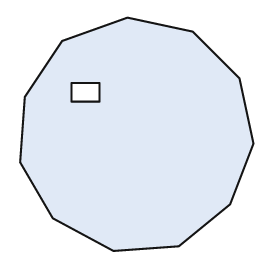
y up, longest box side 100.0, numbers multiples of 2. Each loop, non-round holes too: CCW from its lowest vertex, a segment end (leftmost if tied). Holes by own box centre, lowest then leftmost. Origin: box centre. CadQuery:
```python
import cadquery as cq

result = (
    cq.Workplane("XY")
    .moveTo(-10.0, -50.0)
    .lineTo(18.0, -48.0)
    .lineTo(40.0, -30.0)
    .lineTo(50.0, -4.0)
    .lineTo(44.0, 24.0)
    .lineTo(24.0, 44.0)
    .lineTo(-4.0, 50.0)
    .lineTo(-32.0, 40.0)
    .lineTo(-48.0, 16.0)
    .lineTo(-50.0, -12.0)
    .lineTo(-36.0, -36.0)
    .close()
    .moveTo(-28.0, 14.0)
    .lineTo(-16.0, 14.0)
    .lineTo(-16.0, 22.0)
    .lineTo(-28.0, 22.0)
    .close()
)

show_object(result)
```